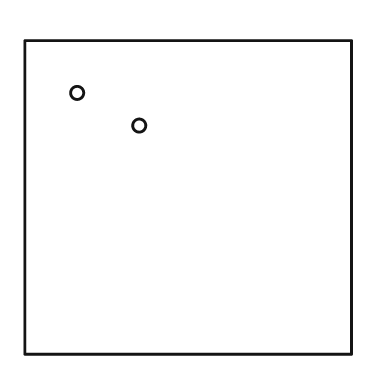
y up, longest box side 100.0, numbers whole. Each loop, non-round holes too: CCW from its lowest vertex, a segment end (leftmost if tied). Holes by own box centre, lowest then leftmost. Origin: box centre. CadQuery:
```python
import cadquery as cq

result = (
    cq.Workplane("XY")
    .moveTo(-50.0, -48.0)
    .lineTo(50.0, -48.0)
    .lineTo(50.0, 48.0)
    .lineTo(-50.0, 48.0)
    .close()
    .moveTo(-15.0, 22.0)
    .circle(2.0)
    .moveTo(-34.0, 32.0)
    .circle(2.0)
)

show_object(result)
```